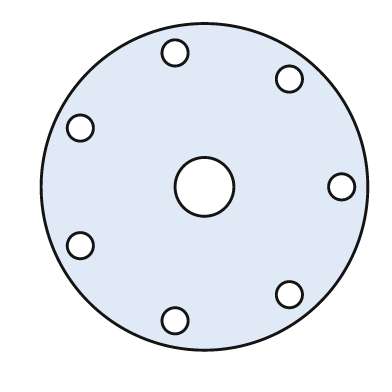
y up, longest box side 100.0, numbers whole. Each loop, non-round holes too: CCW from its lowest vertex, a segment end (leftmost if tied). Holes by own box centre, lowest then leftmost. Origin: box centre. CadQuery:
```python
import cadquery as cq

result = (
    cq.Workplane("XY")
    .moveTo(0.0, 0.0)
    .circle(50.0)
    .moveTo(-9.0, -41.0)
    .circle(4.0)
    .moveTo(26.0, -33.0)
    .circle(4.0)
    .moveTo(-38.0, -18.0)
    .circle(4.0)
    .moveTo(0.0, 0.0)
    .circle(9.0)
    .moveTo(42.0, 0.0)
    .circle(4.0)
    .moveTo(-38.0, 18.0)
    .circle(4.0)
    .moveTo(26.0, 33.0)
    .circle(4.0)
    .moveTo(-9.0, 41.0)
    .circle(4.0)
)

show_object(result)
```